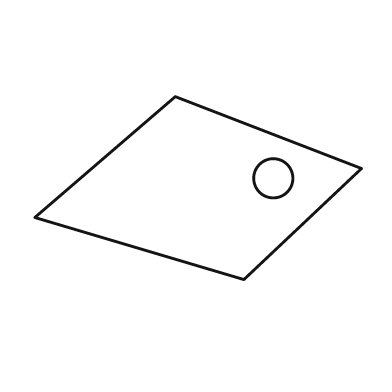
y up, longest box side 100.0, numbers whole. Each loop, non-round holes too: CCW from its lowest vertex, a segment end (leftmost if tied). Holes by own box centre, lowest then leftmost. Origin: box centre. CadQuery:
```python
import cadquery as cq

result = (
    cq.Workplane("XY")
    .moveTo(14.0, -28.0)
    .lineTo(50.0, 6.0)
    .lineTo(-7.0, 28.0)
    .lineTo(-50.0, -9.0)
    .close()
    .moveTo(23.0, 3.0)
    .circle(6.0)
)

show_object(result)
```